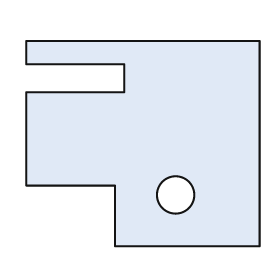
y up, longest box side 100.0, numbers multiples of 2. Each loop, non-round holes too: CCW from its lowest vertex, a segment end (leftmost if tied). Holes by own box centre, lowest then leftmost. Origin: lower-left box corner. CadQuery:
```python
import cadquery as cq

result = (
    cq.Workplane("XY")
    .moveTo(38.0, 0.0)
    .lineTo(100.0, 0.0)
    .lineTo(100.0, 88.0)
    .lineTo(0.0, 88.0)
    .lineTo(0.0, 78.0)
    .lineTo(42.0, 78.0)
    .lineTo(42.0, 66.0)
    .lineTo(0.0, 66.0)
    .lineTo(0.0, 26.0)
    .lineTo(38.0, 26.0)
    .close()
    .moveTo(64.0, 22.0)
    .circle(8.0)
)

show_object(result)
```